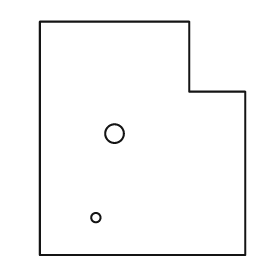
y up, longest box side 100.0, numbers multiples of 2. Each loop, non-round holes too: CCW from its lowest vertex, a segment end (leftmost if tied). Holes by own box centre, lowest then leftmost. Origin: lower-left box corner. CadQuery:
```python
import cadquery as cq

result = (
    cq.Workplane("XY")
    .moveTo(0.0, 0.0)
    .lineTo(88.0, 0.0)
    .lineTo(88.0, 70.0)
    .lineTo(64.0, 70.0)
    .lineTo(64.0, 100.0)
    .lineTo(0.0, 100.0)
    .close()
    .moveTo(24.0, 16.0)
    .circle(2.0)
    .moveTo(32.0, 52.0)
    .circle(4.0)
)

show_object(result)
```